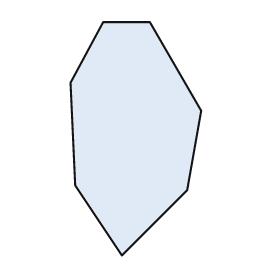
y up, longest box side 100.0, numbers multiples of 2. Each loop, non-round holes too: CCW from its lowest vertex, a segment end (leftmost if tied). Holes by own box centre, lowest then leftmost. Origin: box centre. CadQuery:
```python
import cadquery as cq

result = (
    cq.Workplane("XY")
    .moveTo(-6.0, -50.0)
    .lineTo(22.0, -22.0)
    .lineTo(28.0, 12.0)
    .lineTo(6.0, 50.0)
    .lineTo(-14.0, 50.0)
    .lineTo(-28.0, 24.0)
    .lineTo(-26.0, -20.0)
    .close()
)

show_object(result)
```